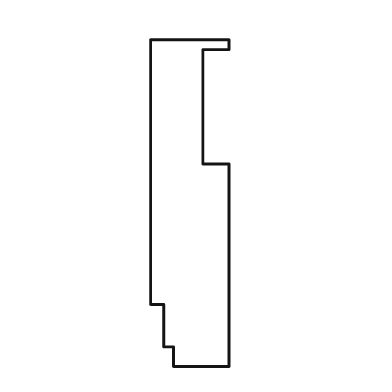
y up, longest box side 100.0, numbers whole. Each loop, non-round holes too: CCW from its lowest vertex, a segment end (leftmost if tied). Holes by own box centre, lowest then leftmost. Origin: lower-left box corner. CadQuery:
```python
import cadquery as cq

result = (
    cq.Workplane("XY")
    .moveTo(7.0, 0.0)
    .lineTo(24.0, 0.0)
    .lineTo(24.0, 62.0)
    .lineTo(16.0, 62.0)
    .lineTo(16.0, 97.0)
    .lineTo(24.0, 97.0)
    .lineTo(24.0, 100.0)
    .lineTo(0.0, 100.0)
    .lineTo(0.0, 19.0)
    .lineTo(4.0, 19.0)
    .lineTo(4.0, 6.0)
    .lineTo(7.0, 6.0)
    .close()
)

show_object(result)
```